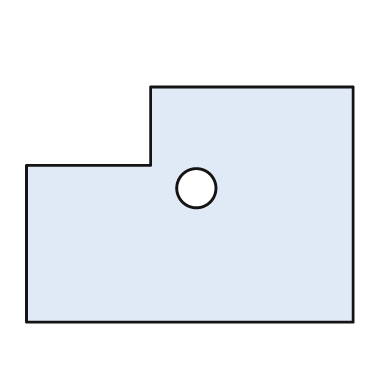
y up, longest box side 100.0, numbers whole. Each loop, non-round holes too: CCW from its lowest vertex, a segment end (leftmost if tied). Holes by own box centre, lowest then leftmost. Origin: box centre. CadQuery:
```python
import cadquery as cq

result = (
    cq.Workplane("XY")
    .moveTo(-50.0, -36.0)
    .lineTo(50.0, -36.0)
    .lineTo(50.0, 36.0)
    .lineTo(-12.0, 36.0)
    .lineTo(-12.0, 12.0)
    .lineTo(-50.0, 12.0)
    .close()
    .moveTo(2.0, 5.0)
    .circle(6.0)
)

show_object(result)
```